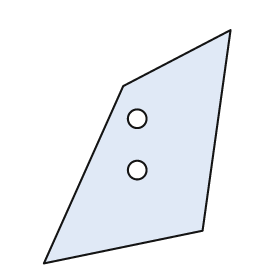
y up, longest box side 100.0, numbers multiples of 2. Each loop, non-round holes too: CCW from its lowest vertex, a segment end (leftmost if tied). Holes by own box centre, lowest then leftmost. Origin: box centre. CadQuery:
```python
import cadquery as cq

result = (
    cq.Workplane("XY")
    .moveTo(-40.0, -50.0)
    .lineTo(28.0, -36.0)
    .lineTo(40.0, 50.0)
    .lineTo(-6.0, 26.0)
    .close()
    .moveTo(0.0, -10.0)
    .circle(4.0)
    .moveTo(0.0, 12.0)
    .circle(4.0)
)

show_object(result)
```